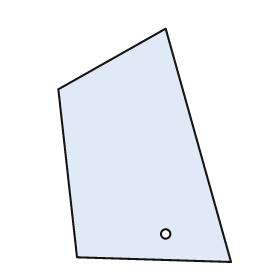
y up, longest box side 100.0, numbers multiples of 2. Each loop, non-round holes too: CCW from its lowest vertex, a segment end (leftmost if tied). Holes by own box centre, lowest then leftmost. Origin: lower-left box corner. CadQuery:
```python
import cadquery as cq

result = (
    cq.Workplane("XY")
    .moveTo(74.0, 0.0)
    .lineTo(46.0, 100.0)
    .lineTo(0.0, 74.0)
    .lineTo(8.0, 2.0)
    .close()
    .moveTo(46.0, 12.0)
    .circle(2.0)
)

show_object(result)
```